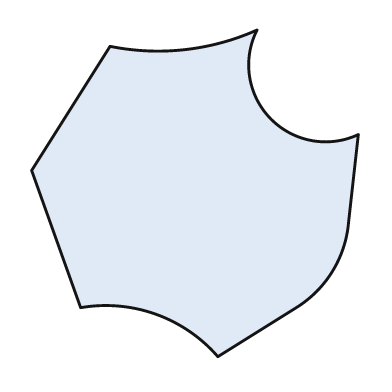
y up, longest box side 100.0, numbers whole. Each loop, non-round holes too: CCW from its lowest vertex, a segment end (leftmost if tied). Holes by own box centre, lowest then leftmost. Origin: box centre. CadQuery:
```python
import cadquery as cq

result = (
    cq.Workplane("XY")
    .moveTo(7.0, -50.0)
    .lineTo(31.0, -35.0)
    .threePointArc((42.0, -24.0), (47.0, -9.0))
    .lineTo(50.0, 18.0)
    .threePointArc((23.0, 23.0), (19.0, 50.0))
    .threePointArc((-3.0, 44.0), (-26.0, 45.0))
    .lineTo(-50.0, 7.0)
    .lineTo(-35.0, -35.0)
    .threePointArc((-12.0, -37.0), (7.0, -50.0))
    .close()
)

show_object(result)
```